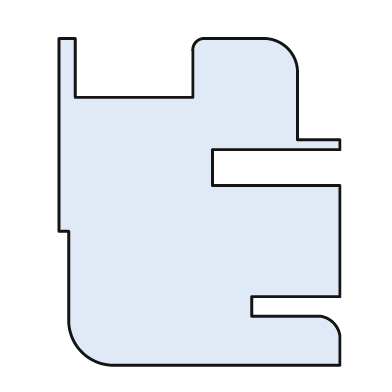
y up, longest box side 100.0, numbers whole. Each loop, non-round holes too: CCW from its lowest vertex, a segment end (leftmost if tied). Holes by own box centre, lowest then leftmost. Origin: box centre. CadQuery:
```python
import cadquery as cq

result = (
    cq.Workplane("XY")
    .moveTo(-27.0, -50.0)
    .lineTo(43.0, -50.0)
    .lineTo(43.0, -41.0)
    .threePointArc((41.0, -37.0), (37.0, -35.0))
    .lineTo(16.0, -35.0)
    .lineTo(16.0, -29.0)
    .lineTo(43.0, -29.0)
    .lineTo(43.0, 5.0)
    .lineTo(4.0, 5.0)
    .lineTo(4.0, 16.0)
    .lineTo(43.0, 16.0)
    .lineTo(43.0, 19.0)
    .lineTo(30.0, 19.0)
    .lineTo(30.0, 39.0)
    .threePointArc((27.0, 47.0), (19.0, 50.0))
    .lineTo(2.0, 50.0)
    .threePointArc((-1.0, 49.0), (-2.0, 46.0))
    .lineTo(-2.0, 32.0)
    .lineTo(-38.0, 32.0)
    .lineTo(-38.0, 50.0)
    .lineTo(-43.0, 50.0)
    .lineTo(-43.0, -9.0)
    .lineTo(-40.0, -9.0)
    .lineTo(-40.0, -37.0)
    .threePointArc((-36.0, -46.0), (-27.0, -50.0))
    .close()
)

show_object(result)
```